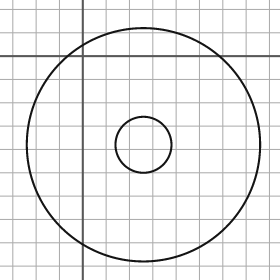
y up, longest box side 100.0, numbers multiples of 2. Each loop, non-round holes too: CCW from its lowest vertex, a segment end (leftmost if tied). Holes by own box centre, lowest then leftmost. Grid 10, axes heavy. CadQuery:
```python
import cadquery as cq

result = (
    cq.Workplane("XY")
    .moveTo(26.0, -38.0)
    .circle(50.0)
    .moveTo(26.0, -38.0)
    .circle(12.0)
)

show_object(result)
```